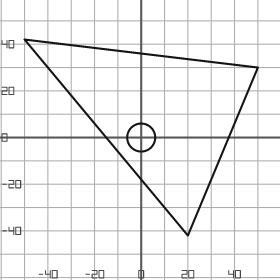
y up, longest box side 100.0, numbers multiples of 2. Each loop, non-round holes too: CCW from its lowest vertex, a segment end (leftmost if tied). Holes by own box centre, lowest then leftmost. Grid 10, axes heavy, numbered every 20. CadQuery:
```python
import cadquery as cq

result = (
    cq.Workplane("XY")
    .moveTo(20.0, -42.0)
    .lineTo(50.0, 30.0)
    .lineTo(-50.0, 42.0)
    .close()
    .moveTo(0.0, 0.0)
    .circle(6.0)
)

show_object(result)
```